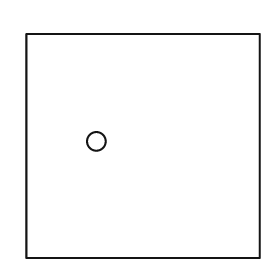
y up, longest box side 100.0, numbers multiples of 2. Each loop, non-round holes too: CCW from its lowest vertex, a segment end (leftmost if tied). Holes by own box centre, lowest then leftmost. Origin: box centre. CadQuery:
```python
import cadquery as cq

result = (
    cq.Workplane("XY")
    .moveTo(-50.0, -48.0)
    .lineTo(50.0, -48.0)
    .lineTo(50.0, 48.0)
    .lineTo(-50.0, 48.0)
    .close()
    .moveTo(-20.0, 2.0)
    .circle(4.0)
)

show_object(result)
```